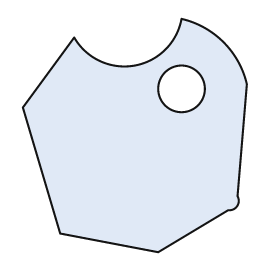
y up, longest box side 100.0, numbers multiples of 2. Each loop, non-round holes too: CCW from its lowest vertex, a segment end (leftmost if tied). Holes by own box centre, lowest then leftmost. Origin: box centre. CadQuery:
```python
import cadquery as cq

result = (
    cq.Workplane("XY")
    .moveTo(10.0, -50.0)
    .lineTo(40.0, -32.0)
    .threePointArc((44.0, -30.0), (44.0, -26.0))
    .lineTo(48.0, 22.0)
    .threePointArc((38.0, 40.0), (20.0, 50.0))
    .threePointArc((0.0, 30.0), (-26.0, 42.0))
    .lineTo(-48.0, 12.0)
    .lineTo(-32.0, -42.0)
    .close()
    .moveTo(20.0, 20.0)
    .circle(10.0)
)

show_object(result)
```